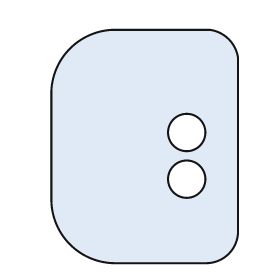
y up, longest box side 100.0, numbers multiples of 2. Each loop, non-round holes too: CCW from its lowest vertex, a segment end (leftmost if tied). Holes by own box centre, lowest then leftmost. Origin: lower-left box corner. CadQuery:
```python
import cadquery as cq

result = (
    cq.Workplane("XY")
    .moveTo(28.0, 0.0)
    .lineTo(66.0, 0.0)
    .threePointArc((76.0, 4.0), (80.0, 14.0))
    .lineTo(80.0, 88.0)
    .threePointArc((76.0, 96.0), (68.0, 100.0))
    .lineTo(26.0, 100.0)
    .threePointArc((8.0, 92.0), (0.0, 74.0))
    .lineTo(0.0, 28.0)
    .threePointArc((8.0, 8.0), (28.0, 0.0))
    .close()
    .moveTo(58.0, 36.0)
    .circle(8.0)
    .moveTo(58.0, 56.0)
    .circle(8.0)
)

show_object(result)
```